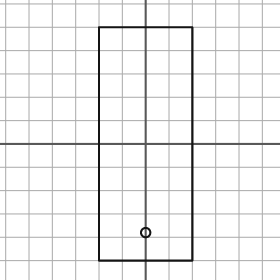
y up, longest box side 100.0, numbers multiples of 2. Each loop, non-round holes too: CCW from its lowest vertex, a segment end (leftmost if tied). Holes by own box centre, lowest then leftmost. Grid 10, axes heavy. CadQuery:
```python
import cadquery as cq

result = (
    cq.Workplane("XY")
    .moveTo(-20.0, -50.0)
    .lineTo(20.0, -50.0)
    .lineTo(20.0, 50.0)
    .lineTo(-20.0, 50.0)
    .close()
    .moveTo(0.0, -38.0)
    .circle(2.0)
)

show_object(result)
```